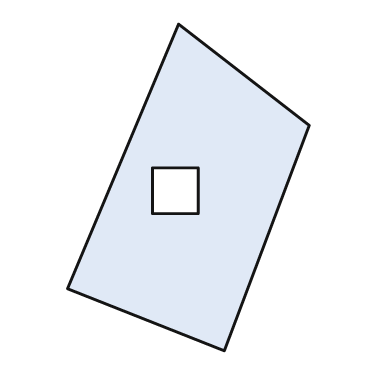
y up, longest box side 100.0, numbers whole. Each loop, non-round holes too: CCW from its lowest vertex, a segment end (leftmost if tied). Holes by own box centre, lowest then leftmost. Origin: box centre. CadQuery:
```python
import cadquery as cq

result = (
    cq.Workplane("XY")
    .moveTo(11.0, -50.0)
    .lineTo(37.0, 19.0)
    .lineTo(-3.0, 50.0)
    .lineTo(-37.0, -31.0)
    .close()
    .moveTo(-11.0, -8.0)
    .lineTo(3.0, -8.0)
    .lineTo(3.0, 6.0)
    .lineTo(-11.0, 6.0)
    .close()
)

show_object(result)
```